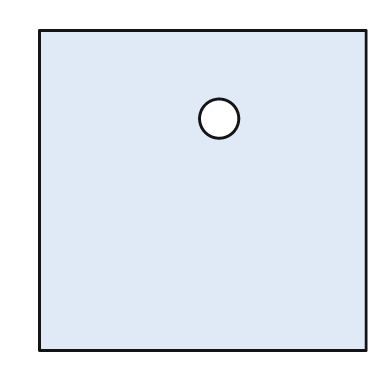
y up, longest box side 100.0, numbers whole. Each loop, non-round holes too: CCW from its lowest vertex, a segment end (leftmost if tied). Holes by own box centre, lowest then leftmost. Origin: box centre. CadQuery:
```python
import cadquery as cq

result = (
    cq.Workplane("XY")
    .moveTo(-50.0, -49.0)
    .lineTo(50.0, -49.0)
    .lineTo(50.0, 49.0)
    .lineTo(-50.0, 49.0)
    .close()
    .moveTo(5.0, 22.0)
    .circle(6.0)
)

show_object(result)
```